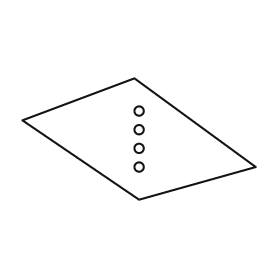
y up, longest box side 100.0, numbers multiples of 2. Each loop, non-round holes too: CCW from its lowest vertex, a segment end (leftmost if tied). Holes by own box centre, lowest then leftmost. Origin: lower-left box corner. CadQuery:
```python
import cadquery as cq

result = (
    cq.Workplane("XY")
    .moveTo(50.0, 0.0)
    .lineTo(100.0, 14.0)
    .lineTo(48.0, 52.0)
    .lineTo(0.0, 34.0)
    .close()
    .moveTo(50.0, 14.0)
    .circle(2.0)
    .moveTo(50.0, 22.0)
    .circle(2.0)
    .moveTo(50.0, 30.0)
    .circle(2.0)
    .moveTo(50.0, 38.0)
    .circle(2.0)
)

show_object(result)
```